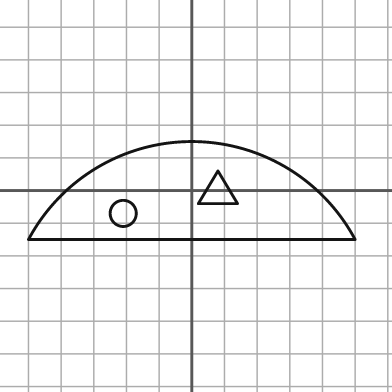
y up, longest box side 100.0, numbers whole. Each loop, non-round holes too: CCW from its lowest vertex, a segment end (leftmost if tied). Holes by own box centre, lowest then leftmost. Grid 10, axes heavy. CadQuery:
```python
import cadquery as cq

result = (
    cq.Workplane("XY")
    .moveTo(-50.0, -15.0)
    .lineTo(50.0, -15.0)
    .threePointArc((0.0, 15.0), (-50.0, -15.0))
    .close()
    .moveTo(-21.0, -7.0)
    .circle(4.0)
    .moveTo(2.0, -4.0)
    .lineTo(14.0, -4.0)
    .lineTo(8.0, 6.0)
    .close()
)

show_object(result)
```